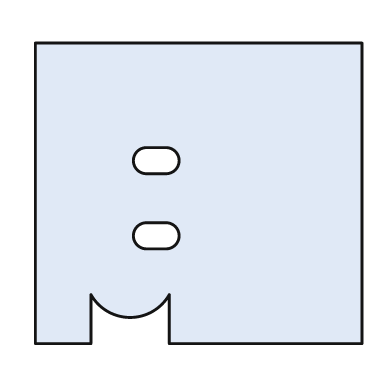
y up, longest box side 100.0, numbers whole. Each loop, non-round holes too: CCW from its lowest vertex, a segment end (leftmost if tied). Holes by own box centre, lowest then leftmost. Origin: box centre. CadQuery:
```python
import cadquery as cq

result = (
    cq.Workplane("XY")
    .moveTo(-50.0, -46.0)
    .lineTo(-33.0, -46.0)
    .lineTo(-33.0, -31.0)
    .threePointArc((-21.0, -38.0), (-9.0, -31.0))
    .lineTo(-9.0, -46.0)
    .lineTo(50.0, -46.0)
    .lineTo(50.0, 46.0)
    .lineTo(-50.0, 46.0)
    .close()
    .moveTo(-16.0, -17.0)
    .lineTo(-10.0, -17.0)
    .threePointArc((-6.0, -13.0), (-10.0, -9.0))
    .lineTo(-16.0, -9.0)
    .threePointArc((-20.0, -13.0), (-16.0, -17.0))
    .close()
    .moveTo(-16.0, 6.0)
    .lineTo(-10.0, 6.0)
    .threePointArc((-6.0, 10.0), (-10.0, 14.0))
    .lineTo(-16.0, 14.0)
    .threePointArc((-20.0, 10.0), (-16.0, 6.0))
    .close()
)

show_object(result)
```